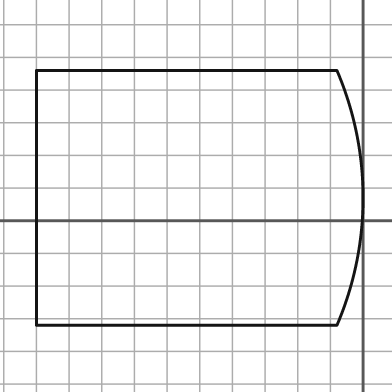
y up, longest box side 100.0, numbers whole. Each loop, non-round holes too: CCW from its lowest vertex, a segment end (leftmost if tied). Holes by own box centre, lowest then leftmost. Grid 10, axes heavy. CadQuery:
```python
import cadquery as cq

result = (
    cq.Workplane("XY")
    .moveTo(-100.0, -32.0)
    .lineTo(-8.0, -32.0)
    .threePointArc((0.0, 7.0), (-8.0, 46.0))
    .lineTo(-100.0, 46.0)
    .close()
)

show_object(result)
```